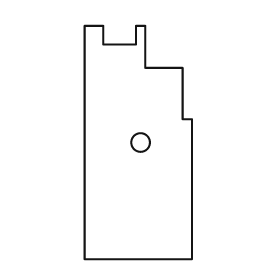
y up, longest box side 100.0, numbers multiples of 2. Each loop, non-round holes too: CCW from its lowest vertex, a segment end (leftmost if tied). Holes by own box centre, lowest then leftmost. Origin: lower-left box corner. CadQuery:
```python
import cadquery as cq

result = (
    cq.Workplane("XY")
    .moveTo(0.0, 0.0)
    .lineTo(46.0, 0.0)
    .lineTo(46.0, 60.0)
    .lineTo(42.0, 60.0)
    .lineTo(42.0, 82.0)
    .lineTo(26.0, 82.0)
    .lineTo(26.0, 100.0)
    .lineTo(22.0, 100.0)
    .lineTo(22.0, 92.0)
    .lineTo(8.0, 92.0)
    .lineTo(8.0, 100.0)
    .lineTo(0.0, 100.0)
    .close()
    .moveTo(24.0, 50.0)
    .circle(4.0)
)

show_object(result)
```